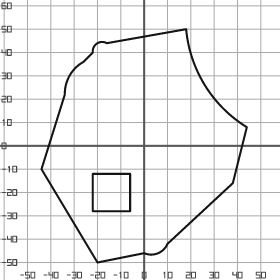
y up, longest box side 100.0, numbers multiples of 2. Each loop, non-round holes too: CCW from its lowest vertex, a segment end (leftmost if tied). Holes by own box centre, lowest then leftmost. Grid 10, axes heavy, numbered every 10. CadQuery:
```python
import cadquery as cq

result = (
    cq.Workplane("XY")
    .moveTo(-20.0, -50.0)
    .lineTo(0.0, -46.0)
    .threePointArc((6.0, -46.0), (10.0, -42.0))
    .lineTo(38.0, -16.0)
    .lineTo(44.0, 8.0)
    .threePointArc((26.0, 26.0), (18.0, 50.0))
    .lineTo(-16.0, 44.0)
    .threePointArc((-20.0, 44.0), (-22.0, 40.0))
    .lineTo(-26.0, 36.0)
    .threePointArc((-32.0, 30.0), (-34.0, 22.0))
    .lineTo(-44.0, -10.0)
    .close()
    .moveTo(-22.0, -28.0)
    .lineTo(-6.0, -28.0)
    .lineTo(-6.0, -12.0)
    .lineTo(-22.0, -12.0)
    .close()
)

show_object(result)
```